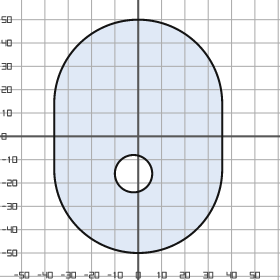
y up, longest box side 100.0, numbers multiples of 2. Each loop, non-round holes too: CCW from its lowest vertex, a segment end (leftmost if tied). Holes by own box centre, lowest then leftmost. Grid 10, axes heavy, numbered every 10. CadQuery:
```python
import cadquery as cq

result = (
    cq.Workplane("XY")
    .moveTo(-36.0, -14.0)
    .threePointArc((0.0, -50.0), (36.0, -14.0))
    .lineTo(36.0, 14.0)
    .threePointArc((0.0, 50.0), (-36.0, 14.0))
    .close()
    .moveTo(-2.0, -16.0)
    .circle(8.0)
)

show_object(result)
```